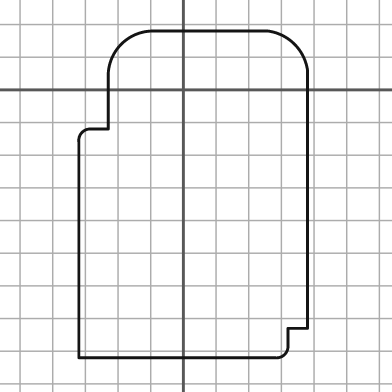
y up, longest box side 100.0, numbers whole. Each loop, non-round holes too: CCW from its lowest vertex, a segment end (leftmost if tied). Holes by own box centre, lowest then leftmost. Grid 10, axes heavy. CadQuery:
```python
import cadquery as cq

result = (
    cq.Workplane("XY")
    .moveTo(-32.0, -82.0)
    .lineTo(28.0, -82.0)
    .threePointArc((31.0, -81.0), (32.0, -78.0))
    .lineTo(32.0, -73.0)
    .lineTo(38.0, -73.0)
    .lineTo(38.0, 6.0)
    .threePointArc((34.0, 14.0), (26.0, 18.0))
    .lineTo(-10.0, 18.0)
    .threePointArc((-19.0, 14.0), (-23.0, 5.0))
    .lineTo(-23.0, -12.0)
    .lineTo(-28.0, -12.0)
    .threePointArc((-31.0, -13.0), (-32.0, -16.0))
    .close()
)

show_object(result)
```